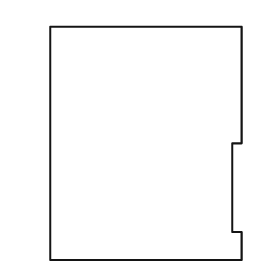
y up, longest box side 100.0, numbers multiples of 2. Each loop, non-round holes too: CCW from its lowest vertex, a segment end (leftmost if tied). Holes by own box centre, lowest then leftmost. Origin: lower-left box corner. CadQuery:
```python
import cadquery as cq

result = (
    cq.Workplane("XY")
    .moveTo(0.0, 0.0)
    .lineTo(82.0, 0.0)
    .lineTo(82.0, 12.0)
    .lineTo(78.0, 12.0)
    .lineTo(78.0, 50.0)
    .lineTo(82.0, 50.0)
    .lineTo(82.0, 100.0)
    .lineTo(0.0, 100.0)
    .close()
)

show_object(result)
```